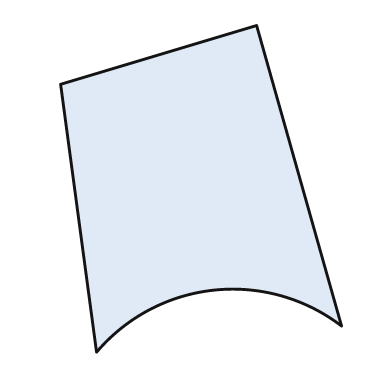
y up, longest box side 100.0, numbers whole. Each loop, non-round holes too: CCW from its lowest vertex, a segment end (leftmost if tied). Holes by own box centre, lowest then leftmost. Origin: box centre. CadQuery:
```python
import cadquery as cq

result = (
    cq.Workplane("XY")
    .moveTo(-32.0, -50.0)
    .threePointArc((4.0, -31.0), (43.0, -42.0))
    .lineTo(17.0, 50.0)
    .lineTo(-43.0, 32.0)
    .close()
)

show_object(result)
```